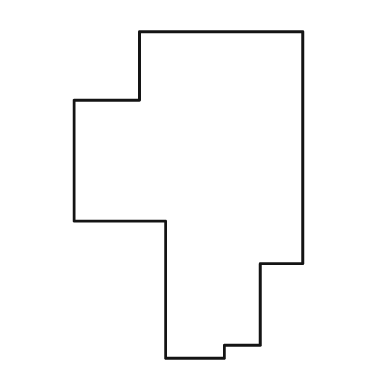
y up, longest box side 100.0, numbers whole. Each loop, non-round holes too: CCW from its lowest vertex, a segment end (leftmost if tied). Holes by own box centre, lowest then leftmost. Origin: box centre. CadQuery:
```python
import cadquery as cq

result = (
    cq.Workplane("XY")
    .moveTo(-7.0, -50.0)
    .lineTo(11.0, -50.0)
    .lineTo(11.0, -46.0)
    .lineTo(22.0, -46.0)
    .lineTo(22.0, -21.0)
    .lineTo(35.0, -21.0)
    .lineTo(35.0, 50.0)
    .lineTo(-15.0, 50.0)
    .lineTo(-15.0, 29.0)
    .lineTo(-35.0, 29.0)
    .lineTo(-35.0, -8.0)
    .lineTo(-7.0, -8.0)
    .close()
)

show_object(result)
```